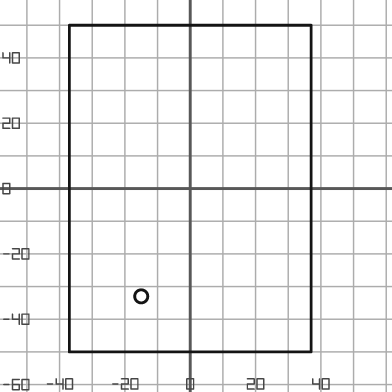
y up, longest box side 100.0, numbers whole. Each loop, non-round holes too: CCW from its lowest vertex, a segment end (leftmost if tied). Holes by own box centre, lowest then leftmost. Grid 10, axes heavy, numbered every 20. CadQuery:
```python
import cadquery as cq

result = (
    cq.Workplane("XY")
    .moveTo(-37.0, -50.0)
    .lineTo(37.0, -50.0)
    .lineTo(37.0, 50.0)
    .lineTo(-37.0, 50.0)
    .close()
    .moveTo(-15.0, -33.0)
    .circle(2.0)
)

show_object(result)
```